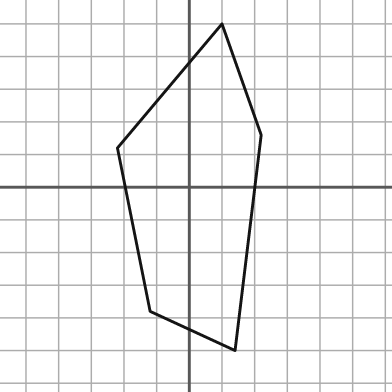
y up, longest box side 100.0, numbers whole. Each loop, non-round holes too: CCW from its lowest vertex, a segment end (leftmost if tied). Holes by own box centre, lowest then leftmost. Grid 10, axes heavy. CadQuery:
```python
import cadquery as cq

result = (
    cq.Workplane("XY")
    .moveTo(14.0, -50.0)
    .lineTo(22.0, 16.0)
    .lineTo(10.0, 50.0)
    .lineTo(-22.0, 12.0)
    .lineTo(-12.0, -38.0)
    .close()
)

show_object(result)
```